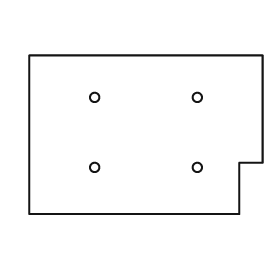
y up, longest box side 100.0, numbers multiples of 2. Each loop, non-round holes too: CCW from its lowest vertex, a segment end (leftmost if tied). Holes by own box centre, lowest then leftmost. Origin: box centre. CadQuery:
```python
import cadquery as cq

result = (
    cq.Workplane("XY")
    .moveTo(-50.0, -34.0)
    .lineTo(40.0, -34.0)
    .lineTo(40.0, -12.0)
    .lineTo(50.0, -12.0)
    .lineTo(50.0, 34.0)
    .lineTo(-50.0, 34.0)
    .close()
    .moveTo(-22.0, -14.0)
    .circle(2.0)
    .moveTo(22.0, -14.0)
    .circle(2.0)
    .moveTo(-22.0, 16.0)
    .circle(2.0)
    .moveTo(22.0, 16.0)
    .circle(2.0)
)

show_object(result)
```